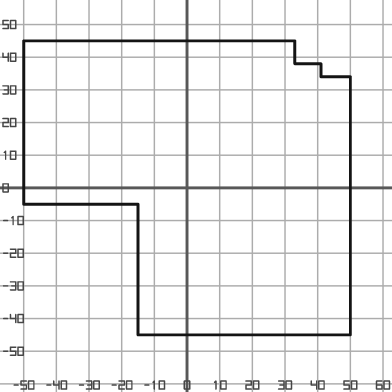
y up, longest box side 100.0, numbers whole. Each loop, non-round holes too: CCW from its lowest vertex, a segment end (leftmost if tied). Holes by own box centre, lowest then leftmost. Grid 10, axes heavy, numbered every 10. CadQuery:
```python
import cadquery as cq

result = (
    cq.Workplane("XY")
    .moveTo(-15.0, -45.0)
    .lineTo(50.0, -45.0)
    .lineTo(50.0, 34.0)
    .lineTo(41.0, 34.0)
    .lineTo(41.0, 38.0)
    .lineTo(33.0, 38.0)
    .lineTo(33.0, 45.0)
    .lineTo(-50.0, 45.0)
    .lineTo(-50.0, -5.0)
    .lineTo(-15.0, -5.0)
    .close()
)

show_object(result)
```